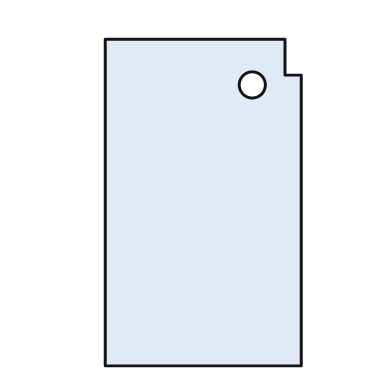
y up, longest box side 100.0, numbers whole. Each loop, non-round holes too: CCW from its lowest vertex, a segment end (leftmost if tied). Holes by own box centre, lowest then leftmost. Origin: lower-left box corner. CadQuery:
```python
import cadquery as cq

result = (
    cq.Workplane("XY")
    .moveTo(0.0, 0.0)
    .lineTo(60.0, 0.0)
    .lineTo(60.0, 89.0)
    .lineTo(55.0, 89.0)
    .lineTo(55.0, 100.0)
    .lineTo(0.0, 100.0)
    .close()
    .moveTo(45.0, 86.0)
    .circle(4.0)
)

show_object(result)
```